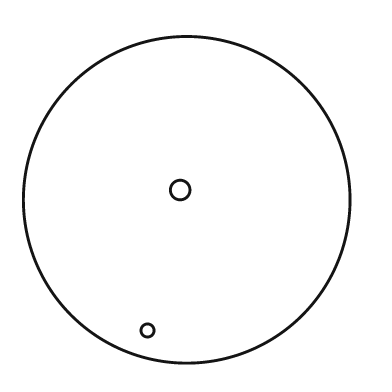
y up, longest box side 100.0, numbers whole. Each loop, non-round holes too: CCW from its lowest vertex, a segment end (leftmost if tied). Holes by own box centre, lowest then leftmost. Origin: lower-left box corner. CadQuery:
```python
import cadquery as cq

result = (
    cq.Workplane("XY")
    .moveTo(50.0, 50.0)
    .circle(50.0)
    .moveTo(38.0, 10.0)
    .circle(2.0)
    .moveTo(48.0, 53.0)
    .circle(3.0)
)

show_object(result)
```